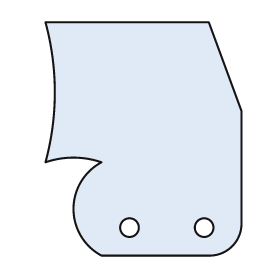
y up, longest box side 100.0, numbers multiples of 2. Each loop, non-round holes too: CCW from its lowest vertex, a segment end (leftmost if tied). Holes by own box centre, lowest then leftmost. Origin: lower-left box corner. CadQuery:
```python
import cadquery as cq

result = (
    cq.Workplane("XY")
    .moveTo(24.0, 0.0)
    .lineTo(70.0, 0.0)
    .threePointArc((80.0, 4.0), (84.0, 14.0))
    .lineTo(84.0, 62.0)
    .lineTo(70.0, 100.0)
    .lineTo(0.0, 100.0)
    .threePointArc((4.0, 70.0), (0.0, 40.0))
    .threePointArc((12.0, 42.0), (24.0, 40.0))
    .threePointArc((12.0, 20.0), (24.0, 0.0))
    .close()
    .moveTo(36.0, 12.0)
    .circle(4.0)
    .moveTo(68.0, 12.0)
    .circle(4.0)
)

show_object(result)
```